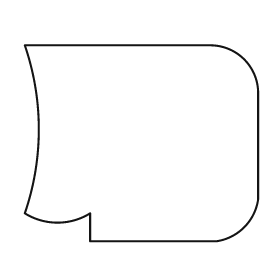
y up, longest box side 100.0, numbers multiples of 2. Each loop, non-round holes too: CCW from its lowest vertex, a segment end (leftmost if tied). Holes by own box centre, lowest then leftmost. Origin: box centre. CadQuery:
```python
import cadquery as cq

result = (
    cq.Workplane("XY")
    .moveTo(-22.0, -42.0)
    .lineTo(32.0, -42.0)
    .threePointArc((44.0, -36.0), (50.0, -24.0))
    .lineTo(50.0, 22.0)
    .threePointArc((44.0, 36.0), (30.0, 42.0))
    .lineTo(-50.0, 42.0)
    .threePointArc((-44.0, 6.0), (-50.0, -30.0))
    .threePointArc((-36.0, -34.0), (-22.0, -30.0))
    .close()
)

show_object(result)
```